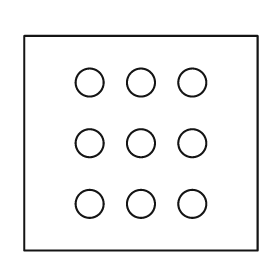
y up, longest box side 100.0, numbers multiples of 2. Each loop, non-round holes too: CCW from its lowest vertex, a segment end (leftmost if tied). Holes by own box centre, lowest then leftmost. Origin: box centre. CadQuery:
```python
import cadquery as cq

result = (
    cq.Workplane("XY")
    .moveTo(-50.0, -46.0)
    .lineTo(50.0, -46.0)
    .lineTo(50.0, 46.0)
    .lineTo(-50.0, 46.0)
    .close()
    .moveTo(-22.0, -26.0)
    .circle(6.0)
    .moveTo(0.0, -26.0)
    .circle(6.0)
    .moveTo(22.0, -26.0)
    .circle(6.0)
    .moveTo(-22.0, 0.0)
    .circle(6.0)
    .moveTo(0.0, 0.0)
    .circle(6.0)
    .moveTo(22.0, 0.0)
    .circle(6.0)
    .moveTo(-22.0, 26.0)
    .circle(6.0)
    .moveTo(0.0, 26.0)
    .circle(6.0)
    .moveTo(22.0, 26.0)
    .circle(6.0)
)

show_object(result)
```